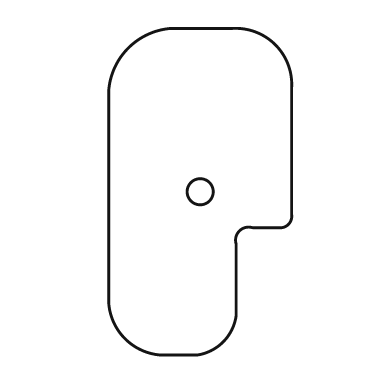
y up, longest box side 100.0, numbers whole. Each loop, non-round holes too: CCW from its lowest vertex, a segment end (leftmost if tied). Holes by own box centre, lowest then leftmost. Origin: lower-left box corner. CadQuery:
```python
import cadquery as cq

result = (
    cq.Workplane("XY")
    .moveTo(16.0, 0.0)
    .lineTo(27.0, 0.0)
    .threePointArc((35.0, 4.0), (39.0, 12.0))
    .lineTo(39.0, 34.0)
    .threePointArc((40.0, 38.0), (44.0, 39.0))
    .lineTo(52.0, 39.0)
    .threePointArc((55.0, 40.0), (56.0, 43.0))
    .lineTo(56.0, 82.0)
    .threePointArc((51.0, 95.0), (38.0, 100.0))
    .lineTo(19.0, 100.0)
    .threePointArc((6.0, 94.0), (0.0, 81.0))
    .lineTo(0.0, 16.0)
    .threePointArc((5.0, 5.0), (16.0, 0.0))
    .close()
    .moveTo(28.0, 50.0)
    .circle(4.0)
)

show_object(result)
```